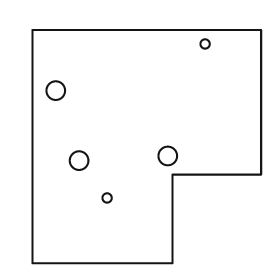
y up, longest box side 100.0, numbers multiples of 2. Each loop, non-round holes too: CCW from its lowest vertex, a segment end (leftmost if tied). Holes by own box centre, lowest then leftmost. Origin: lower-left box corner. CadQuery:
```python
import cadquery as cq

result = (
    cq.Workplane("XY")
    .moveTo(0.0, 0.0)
    .lineTo(60.0, 0.0)
    .lineTo(60.0, 38.0)
    .lineTo(98.0, 38.0)
    .lineTo(98.0, 100.0)
    .lineTo(0.0, 100.0)
    .close()
    .moveTo(32.0, 28.0)
    .circle(2.0)
    .moveTo(20.0, 44.0)
    .circle(4.0)
    .moveTo(58.0, 46.0)
    .circle(4.0)
    .moveTo(10.0, 74.0)
    .circle(4.0)
    .moveTo(74.0, 94.0)
    .circle(2.0)
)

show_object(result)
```